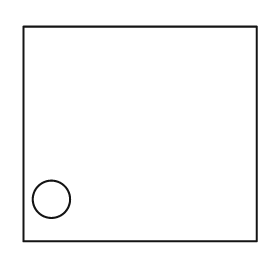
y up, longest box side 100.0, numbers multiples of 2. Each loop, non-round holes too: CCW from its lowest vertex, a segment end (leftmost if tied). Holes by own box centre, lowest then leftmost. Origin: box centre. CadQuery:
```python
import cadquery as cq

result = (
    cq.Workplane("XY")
    .moveTo(-50.0, -46.0)
    .lineTo(50.0, -46.0)
    .lineTo(50.0, 46.0)
    .lineTo(-50.0, 46.0)
    .close()
    .moveTo(-38.0, -28.0)
    .circle(8.0)
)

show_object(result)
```